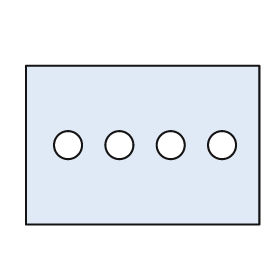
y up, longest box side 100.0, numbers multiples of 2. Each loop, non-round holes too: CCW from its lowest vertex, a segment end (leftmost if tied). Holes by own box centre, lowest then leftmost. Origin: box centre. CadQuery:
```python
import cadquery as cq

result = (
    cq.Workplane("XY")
    .moveTo(-50.0, -34.0)
    .lineTo(50.0, -34.0)
    .lineTo(50.0, 34.0)
    .lineTo(-50.0, 34.0)
    .close()
    .moveTo(-32.0, 0.0)
    .circle(6.0)
    .moveTo(-10.0, 0.0)
    .circle(6.0)
    .moveTo(12.0, 0.0)
    .circle(6.0)
    .moveTo(34.0, 0.0)
    .circle(6.0)
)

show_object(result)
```